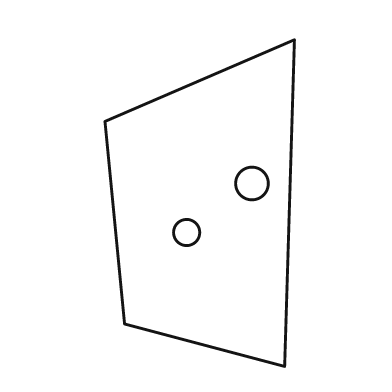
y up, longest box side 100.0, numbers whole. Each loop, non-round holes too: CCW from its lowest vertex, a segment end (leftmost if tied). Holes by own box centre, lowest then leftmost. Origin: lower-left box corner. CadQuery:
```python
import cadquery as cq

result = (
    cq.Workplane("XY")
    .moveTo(55.0, 0.0)
    .lineTo(58.0, 100.0)
    .lineTo(0.0, 75.0)
    .lineTo(6.0, 13.0)
    .close()
    .moveTo(25.0, 41.0)
    .circle(4.0)
    .moveTo(45.0, 56.0)
    .circle(5.0)
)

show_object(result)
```